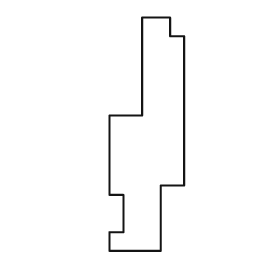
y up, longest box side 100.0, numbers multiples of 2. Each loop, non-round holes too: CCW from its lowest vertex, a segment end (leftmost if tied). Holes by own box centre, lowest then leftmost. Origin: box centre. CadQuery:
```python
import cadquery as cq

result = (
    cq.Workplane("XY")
    .moveTo(-16.0, -50.0)
    .lineTo(6.0, -50.0)
    .lineTo(6.0, -22.0)
    .lineTo(16.0, -22.0)
    .lineTo(16.0, 42.0)
    .lineTo(10.0, 42.0)
    .lineTo(10.0, 50.0)
    .lineTo(-2.0, 50.0)
    .lineTo(-2.0, 8.0)
    .lineTo(-16.0, 8.0)
    .lineTo(-16.0, -26.0)
    .lineTo(-10.0, -26.0)
    .lineTo(-10.0, -42.0)
    .lineTo(-16.0, -42.0)
    .close()
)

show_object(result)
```